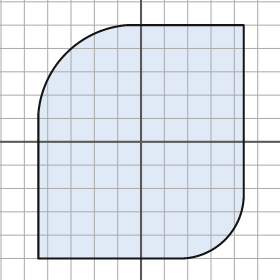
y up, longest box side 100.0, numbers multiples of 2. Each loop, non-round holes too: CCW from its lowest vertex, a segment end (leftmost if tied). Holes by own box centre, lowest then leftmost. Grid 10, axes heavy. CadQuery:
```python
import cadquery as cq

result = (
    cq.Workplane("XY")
    .moveTo(-44.0, -50.0)
    .lineTo(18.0, -50.0)
    .threePointArc((36.0, -42.0), (44.0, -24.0))
    .lineTo(44.0, 50.0)
    .lineTo(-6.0, 50.0)
    .threePointArc((-32.0, 38.0), (-44.0, 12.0))
    .close()
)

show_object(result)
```